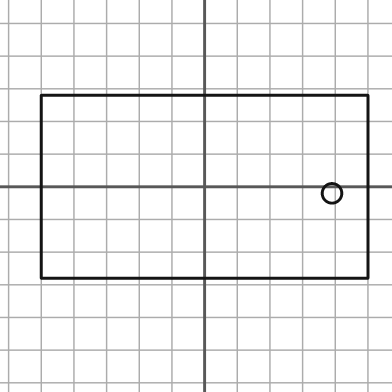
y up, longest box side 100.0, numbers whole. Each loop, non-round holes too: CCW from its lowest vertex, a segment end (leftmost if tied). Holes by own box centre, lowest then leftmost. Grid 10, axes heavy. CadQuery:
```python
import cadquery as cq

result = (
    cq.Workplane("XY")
    .moveTo(-50.0, -28.0)
    .lineTo(50.0, -28.0)
    .lineTo(50.0, 28.0)
    .lineTo(-50.0, 28.0)
    .close()
    .moveTo(39.0, -2.0)
    .circle(3.0)
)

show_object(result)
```